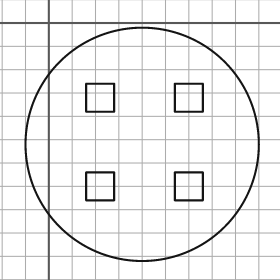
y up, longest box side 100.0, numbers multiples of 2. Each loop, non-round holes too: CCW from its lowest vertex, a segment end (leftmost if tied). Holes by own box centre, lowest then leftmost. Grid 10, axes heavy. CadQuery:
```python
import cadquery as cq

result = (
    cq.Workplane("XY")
    .moveTo(40.0, -52.0)
    .circle(50.0)
    .moveTo(16.0, -76.0)
    .lineTo(28.0, -76.0)
    .lineTo(28.0, -64.0)
    .lineTo(16.0, -64.0)
    .close()
    .moveTo(54.0, -76.0)
    .lineTo(66.0, -76.0)
    .lineTo(66.0, -64.0)
    .lineTo(54.0, -64.0)
    .close()
    .moveTo(16.0, -38.0)
    .lineTo(28.0, -38.0)
    .lineTo(28.0, -26.0)
    .lineTo(16.0, -26.0)
    .close()
    .moveTo(54.0, -38.0)
    .lineTo(66.0, -38.0)
    .lineTo(66.0, -26.0)
    .lineTo(54.0, -26.0)
    .close()
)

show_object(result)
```